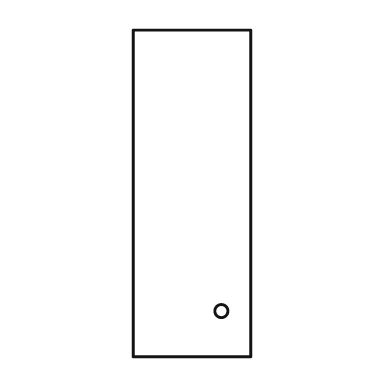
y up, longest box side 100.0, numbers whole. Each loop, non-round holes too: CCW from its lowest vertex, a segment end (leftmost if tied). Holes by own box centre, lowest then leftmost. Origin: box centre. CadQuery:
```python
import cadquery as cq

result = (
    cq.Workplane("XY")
    .moveTo(-18.0, -50.0)
    .lineTo(18.0, -50.0)
    .lineTo(18.0, 50.0)
    .lineTo(-18.0, 50.0)
    .close()
    .moveTo(9.0, -36.0)
    .circle(2.0)
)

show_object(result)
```